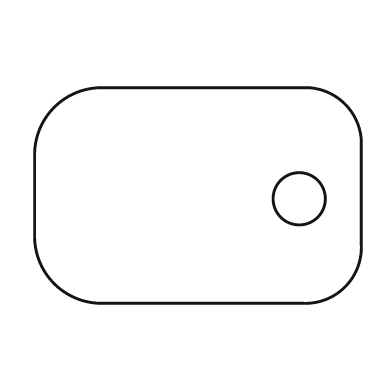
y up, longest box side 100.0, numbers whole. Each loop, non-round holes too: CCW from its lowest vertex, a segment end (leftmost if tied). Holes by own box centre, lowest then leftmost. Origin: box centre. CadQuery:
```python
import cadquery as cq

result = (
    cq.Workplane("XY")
    .moveTo(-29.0, -33.0)
    .lineTo(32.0, -33.0)
    .threePointArc((45.0, -28.0), (50.0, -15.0))
    .lineTo(50.0, 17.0)
    .threePointArc((45.0, 28.0), (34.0, 33.0))
    .lineTo(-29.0, 33.0)
    .threePointArc((-44.0, 27.0), (-50.0, 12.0))
    .lineTo(-50.0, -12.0)
    .threePointArc((-44.0, -27.0), (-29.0, -33.0))
    .close()
    .moveTo(31.0, -1.0)
    .circle(8.0)
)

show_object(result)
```